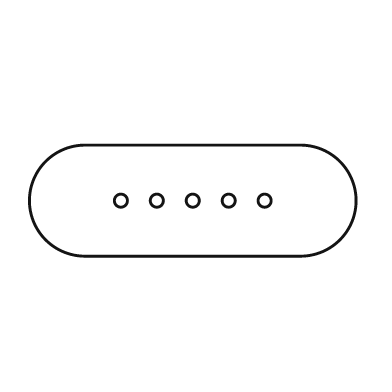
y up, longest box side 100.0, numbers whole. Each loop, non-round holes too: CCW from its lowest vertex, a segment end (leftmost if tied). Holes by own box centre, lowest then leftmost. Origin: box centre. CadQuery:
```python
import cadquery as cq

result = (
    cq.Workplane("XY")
    .moveTo(-33.0, -17.0)
    .lineTo(33.0, -17.0)
    .threePointArc((50.0, 0.0), (33.0, 17.0))
    .lineTo(-33.0, 17.0)
    .threePointArc((-50.0, 0.0), (-33.0, -17.0))
    .close()
    .moveTo(-22.0, 0.0)
    .circle(2.0)
    .moveTo(-11.0, 0.0)
    .circle(2.0)
    .moveTo(0.0, 0.0)
    .circle(2.0)
    .moveTo(11.0, 0.0)
    .circle(2.0)
    .moveTo(22.0, 0.0)
    .circle(2.0)
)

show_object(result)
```